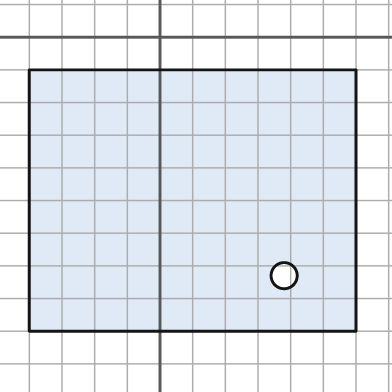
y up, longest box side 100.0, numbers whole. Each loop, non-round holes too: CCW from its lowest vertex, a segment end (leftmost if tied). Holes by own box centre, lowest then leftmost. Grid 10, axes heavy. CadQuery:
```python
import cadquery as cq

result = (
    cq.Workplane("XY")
    .moveTo(-40.0, -90.0)
    .lineTo(60.0, -90.0)
    .lineTo(60.0, -10.0)
    .lineTo(-40.0, -10.0)
    .close()
    .moveTo(38.0, -73.0)
    .circle(4.0)
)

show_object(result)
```